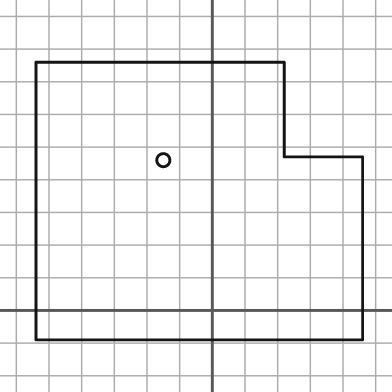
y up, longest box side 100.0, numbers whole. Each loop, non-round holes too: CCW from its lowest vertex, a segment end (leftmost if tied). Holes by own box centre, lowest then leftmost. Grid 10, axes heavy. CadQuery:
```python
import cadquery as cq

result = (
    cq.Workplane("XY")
    .moveTo(-54.0, -9.0)
    .lineTo(46.0, -9.0)
    .lineTo(46.0, 47.0)
    .lineTo(22.0, 47.0)
    .lineTo(22.0, 76.0)
    .lineTo(-54.0, 76.0)
    .close()
    .moveTo(-15.0, 46.0)
    .circle(2.0)
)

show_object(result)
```